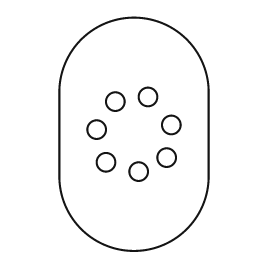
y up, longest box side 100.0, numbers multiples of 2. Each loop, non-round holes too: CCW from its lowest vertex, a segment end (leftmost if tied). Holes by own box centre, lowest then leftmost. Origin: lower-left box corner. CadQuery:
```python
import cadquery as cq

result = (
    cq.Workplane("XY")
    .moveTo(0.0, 32.0)
    .threePointArc((32.0, 0.0), (64.0, 32.0))
    .lineTo(64.0, 68.0)
    .threePointArc((32.0, 100.0), (0.0, 68.0))
    .close()
    .moveTo(34.0, 34.0)
    .circle(4.0)
    .moveTo(20.0, 38.0)
    .circle(4.0)
    .moveTo(46.0, 40.0)
    .circle(4.0)
    .moveTo(16.0, 52.0)
    .circle(4.0)
    .moveTo(48.0, 54.0)
    .circle(4.0)
    .moveTo(24.0, 64.0)
    .circle(4.0)
    .moveTo(38.0, 66.0)
    .circle(4.0)
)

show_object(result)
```